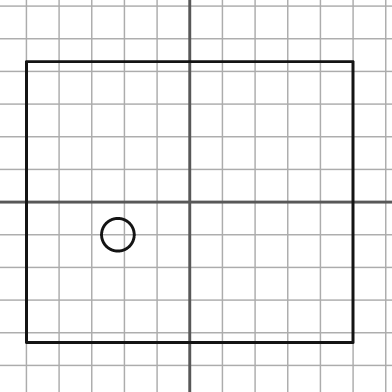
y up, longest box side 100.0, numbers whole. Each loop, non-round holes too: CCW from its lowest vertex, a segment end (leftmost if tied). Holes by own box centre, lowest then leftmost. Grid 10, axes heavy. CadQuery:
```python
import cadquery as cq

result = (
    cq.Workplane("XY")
    .moveTo(-50.0, -43.0)
    .lineTo(50.0, -43.0)
    .lineTo(50.0, 43.0)
    .lineTo(-50.0, 43.0)
    .close()
    .moveTo(-22.0, -10.0)
    .circle(5.0)
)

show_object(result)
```